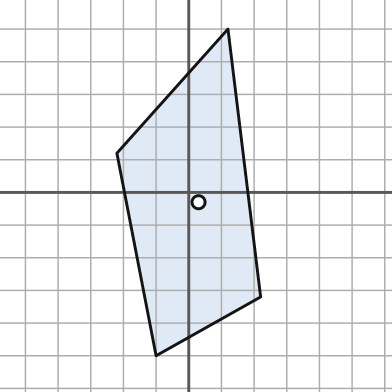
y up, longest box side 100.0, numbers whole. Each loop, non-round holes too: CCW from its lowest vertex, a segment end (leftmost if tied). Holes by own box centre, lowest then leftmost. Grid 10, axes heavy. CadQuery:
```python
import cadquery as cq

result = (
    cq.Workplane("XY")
    .moveTo(-10.0, -50.0)
    .lineTo(22.0, -32.0)
    .lineTo(12.0, 50.0)
    .lineTo(-22.0, 12.0)
    .close()
    .moveTo(3.0, -3.0)
    .circle(2.0)
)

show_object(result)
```